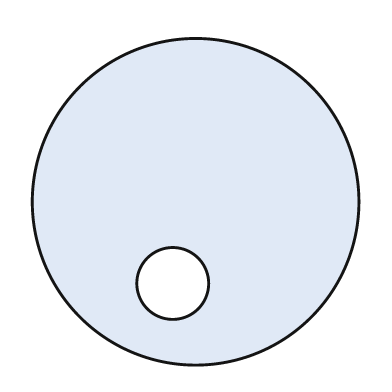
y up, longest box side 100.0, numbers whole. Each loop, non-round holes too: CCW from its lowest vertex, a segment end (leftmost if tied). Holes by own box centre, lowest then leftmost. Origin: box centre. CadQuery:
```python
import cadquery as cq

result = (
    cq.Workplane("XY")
    .moveTo(0.0, 0.0)
    .circle(50.0)
    .moveTo(-7.0, -25.0)
    .circle(11.0)
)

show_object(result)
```